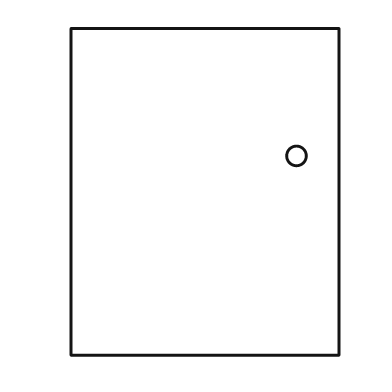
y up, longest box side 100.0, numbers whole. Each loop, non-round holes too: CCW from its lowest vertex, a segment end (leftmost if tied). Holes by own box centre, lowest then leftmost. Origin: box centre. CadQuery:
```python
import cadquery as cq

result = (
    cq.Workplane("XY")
    .moveTo(-41.0, -50.0)
    .lineTo(41.0, -50.0)
    .lineTo(41.0, 50.0)
    .lineTo(-41.0, 50.0)
    .close()
    .moveTo(28.0, 11.0)
    .circle(3.0)
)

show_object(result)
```